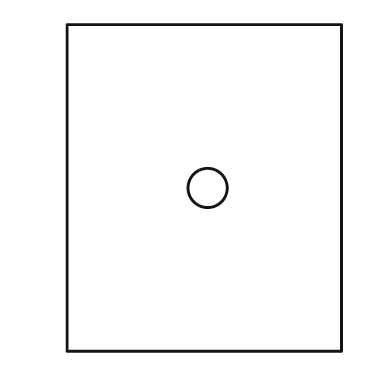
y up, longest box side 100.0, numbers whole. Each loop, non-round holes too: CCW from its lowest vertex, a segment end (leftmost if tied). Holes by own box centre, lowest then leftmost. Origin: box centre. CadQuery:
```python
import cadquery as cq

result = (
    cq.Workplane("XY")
    .moveTo(-42.0, -50.0)
    .lineTo(42.0, -50.0)
    .lineTo(42.0, 50.0)
    .lineTo(-42.0, 50.0)
    .close()
    .moveTo(1.0, 0.0)
    .circle(6.0)
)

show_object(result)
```